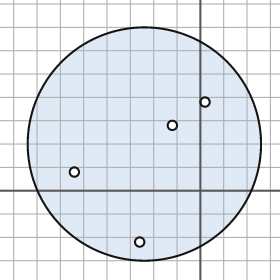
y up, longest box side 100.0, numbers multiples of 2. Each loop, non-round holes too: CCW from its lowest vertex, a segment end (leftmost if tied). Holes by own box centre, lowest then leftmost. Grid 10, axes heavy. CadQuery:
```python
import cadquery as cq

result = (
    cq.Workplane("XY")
    .moveTo(-24.0, 20.0)
    .circle(50.0)
    .moveTo(-26.0, -22.0)
    .circle(2.0)
    .moveTo(-54.0, 8.0)
    .circle(2.0)
    .moveTo(-12.0, 28.0)
    .circle(2.0)
    .moveTo(2.0, 38.0)
    .circle(2.0)
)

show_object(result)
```